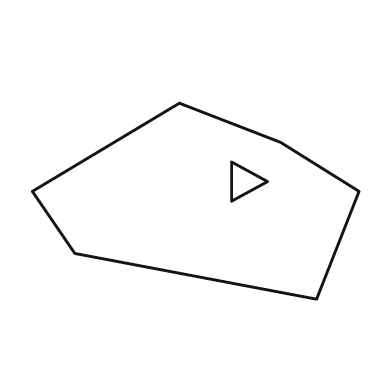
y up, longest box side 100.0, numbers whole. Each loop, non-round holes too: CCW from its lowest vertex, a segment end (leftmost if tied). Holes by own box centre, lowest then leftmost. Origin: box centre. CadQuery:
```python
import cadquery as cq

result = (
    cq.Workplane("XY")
    .moveTo(37.0, -30.0)
    .lineTo(50.0, 3.0)
    .lineTo(26.0, 18.0)
    .lineTo(-5.0, 30.0)
    .lineTo(-50.0, 3.0)
    .lineTo(-37.0, -16.0)
    .close()
    .moveTo(11.0, 0.0)
    .lineTo(22.0, 6.0)
    .lineTo(11.0, 12.0)
    .close()
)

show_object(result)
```